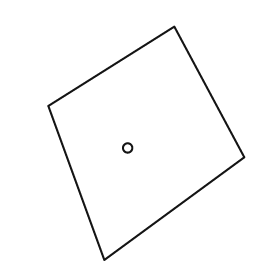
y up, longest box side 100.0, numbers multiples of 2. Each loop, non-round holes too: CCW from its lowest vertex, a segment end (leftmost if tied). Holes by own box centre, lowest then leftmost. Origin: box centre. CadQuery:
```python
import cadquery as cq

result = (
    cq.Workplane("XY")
    .moveTo(-18.0, -50.0)
    .lineTo(42.0, -6.0)
    .lineTo(12.0, 50.0)
    .lineTo(-42.0, 16.0)
    .close()
    .moveTo(-8.0, -2.0)
    .circle(2.0)
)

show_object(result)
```